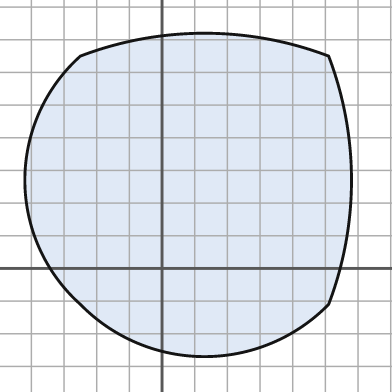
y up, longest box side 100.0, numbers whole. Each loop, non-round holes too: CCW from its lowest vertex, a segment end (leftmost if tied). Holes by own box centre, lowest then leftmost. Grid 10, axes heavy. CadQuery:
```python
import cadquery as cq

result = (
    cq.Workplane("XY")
    .moveTo(-25.0, -11.0)
    .threePointArc((13.0, -27.0), (51.0, -11.0))
    .threePointArc((58.0, 27.0), (51.0, 65.0))
    .threePointArc((13.0, 72.0), (-25.0, 65.0))
    .threePointArc((-42.0, 27.0), (-25.0, -11.0))
    .close()
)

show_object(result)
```